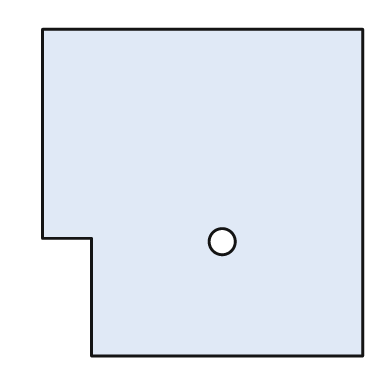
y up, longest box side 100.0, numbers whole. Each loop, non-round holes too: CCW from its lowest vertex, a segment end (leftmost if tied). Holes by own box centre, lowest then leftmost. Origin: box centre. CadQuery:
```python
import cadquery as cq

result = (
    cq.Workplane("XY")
    .moveTo(-34.0, -50.0)
    .lineTo(49.0, -50.0)
    .lineTo(49.0, 50.0)
    .lineTo(-49.0, 50.0)
    .lineTo(-49.0, -14.0)
    .lineTo(-34.0, -14.0)
    .close()
    .moveTo(6.0, -15.0)
    .circle(4.0)
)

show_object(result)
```